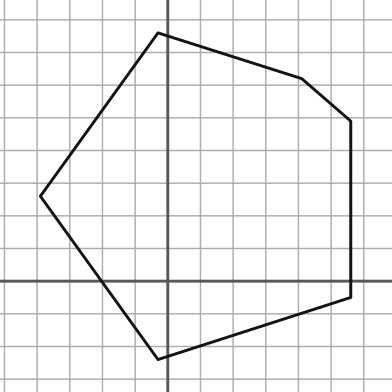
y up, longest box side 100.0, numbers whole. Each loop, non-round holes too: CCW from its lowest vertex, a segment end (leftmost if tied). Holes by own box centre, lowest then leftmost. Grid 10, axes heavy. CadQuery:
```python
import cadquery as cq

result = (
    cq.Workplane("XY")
    .moveTo(-3.0, -24.0)
    .lineTo(56.0, -5.0)
    .lineTo(56.0, 49.0)
    .lineTo(41.0, 62.0)
    .lineTo(-3.0, 76.0)
    .lineTo(-39.0, 26.0)
    .close()
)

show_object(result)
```